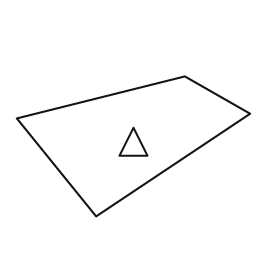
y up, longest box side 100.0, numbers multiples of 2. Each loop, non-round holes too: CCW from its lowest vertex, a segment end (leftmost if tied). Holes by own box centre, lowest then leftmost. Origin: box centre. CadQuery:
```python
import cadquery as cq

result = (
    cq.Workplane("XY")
    .moveTo(-16.0, -30.0)
    .lineTo(50.0, 14.0)
    .lineTo(22.0, 30.0)
    .lineTo(-50.0, 12.0)
    .close()
    .moveTo(-6.0, -4.0)
    .lineTo(6.0, -4.0)
    .lineTo(0.0, 8.0)
    .close()
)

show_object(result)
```